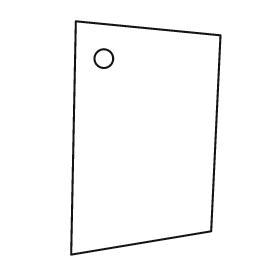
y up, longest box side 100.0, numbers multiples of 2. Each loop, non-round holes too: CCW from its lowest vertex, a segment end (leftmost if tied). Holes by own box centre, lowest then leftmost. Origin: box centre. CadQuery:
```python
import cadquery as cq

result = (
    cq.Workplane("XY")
    .moveTo(-32.0, -50.0)
    .lineTo(28.0, -40.0)
    .lineTo(32.0, 44.0)
    .lineTo(-30.0, 50.0)
    .close()
    .moveTo(-18.0, 34.0)
    .circle(4.0)
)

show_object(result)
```